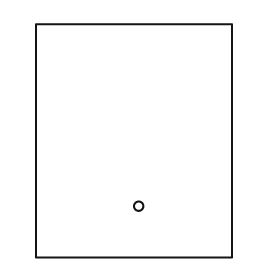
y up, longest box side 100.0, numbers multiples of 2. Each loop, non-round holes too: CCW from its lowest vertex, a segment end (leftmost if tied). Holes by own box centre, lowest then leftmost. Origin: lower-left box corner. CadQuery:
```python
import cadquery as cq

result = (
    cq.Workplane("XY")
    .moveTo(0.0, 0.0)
    .lineTo(84.0, 0.0)
    .lineTo(84.0, 100.0)
    .lineTo(0.0, 100.0)
    .close()
    .moveTo(44.0, 22.0)
    .circle(2.0)
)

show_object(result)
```